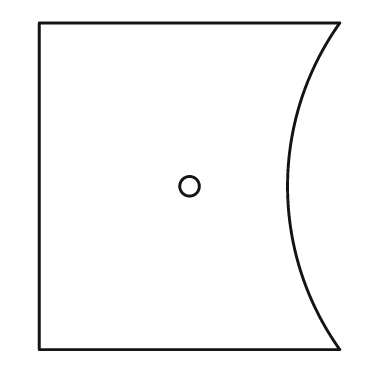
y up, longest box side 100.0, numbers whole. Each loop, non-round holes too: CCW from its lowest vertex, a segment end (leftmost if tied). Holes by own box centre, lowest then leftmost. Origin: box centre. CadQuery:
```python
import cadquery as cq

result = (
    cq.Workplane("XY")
    .moveTo(-46.0, -50.0)
    .lineTo(46.0, -50.0)
    .threePointArc((30.0, 0.0), (46.0, 50.0))
    .lineTo(-46.0, 50.0)
    .close()
    .moveTo(0.0, 0.0)
    .circle(3.0)
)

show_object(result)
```